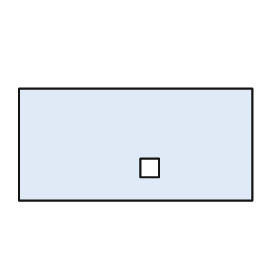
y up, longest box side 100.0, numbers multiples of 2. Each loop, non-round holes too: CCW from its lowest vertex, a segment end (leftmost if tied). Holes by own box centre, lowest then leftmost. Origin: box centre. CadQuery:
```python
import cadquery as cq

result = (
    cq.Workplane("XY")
    .moveTo(-50.0, -24.0)
    .lineTo(50.0, -24.0)
    .lineTo(50.0, 24.0)
    .lineTo(-50.0, 24.0)
    .close()
    .moveTo(2.0, -14.0)
    .lineTo(10.0, -14.0)
    .lineTo(10.0, -6.0)
    .lineTo(2.0, -6.0)
    .close()
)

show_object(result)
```